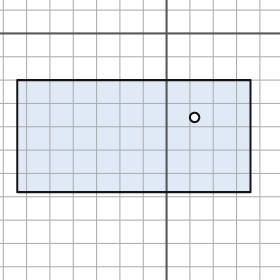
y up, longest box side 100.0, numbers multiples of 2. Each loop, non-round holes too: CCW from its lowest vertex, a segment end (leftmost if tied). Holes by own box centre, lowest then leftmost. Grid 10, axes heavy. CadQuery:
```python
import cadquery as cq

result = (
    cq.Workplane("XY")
    .moveTo(-64.0, -68.0)
    .lineTo(36.0, -68.0)
    .lineTo(36.0, -20.0)
    .lineTo(-64.0, -20.0)
    .close()
    .moveTo(12.0, -36.0)
    .circle(2.0)
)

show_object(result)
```